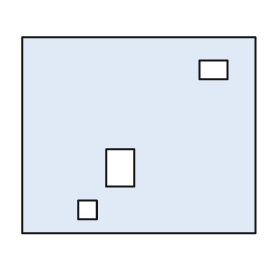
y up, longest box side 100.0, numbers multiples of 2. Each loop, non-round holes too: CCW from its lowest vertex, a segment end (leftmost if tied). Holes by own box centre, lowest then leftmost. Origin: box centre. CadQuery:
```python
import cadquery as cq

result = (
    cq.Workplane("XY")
    .moveTo(-50.0, -42.0)
    .lineTo(50.0, -42.0)
    .lineTo(50.0, 42.0)
    .lineTo(-50.0, 42.0)
    .close()
    .moveTo(-26.0, -36.0)
    .lineTo(-18.0, -36.0)
    .lineTo(-18.0, -28.0)
    .lineTo(-26.0, -28.0)
    .close()
    .moveTo(-14.0, -22.0)
    .lineTo(-2.0, -22.0)
    .lineTo(-2.0, -6.0)
    .lineTo(-14.0, -6.0)
    .close()
    .moveTo(26.0, 24.0)
    .lineTo(38.0, 24.0)
    .lineTo(38.0, 32.0)
    .lineTo(26.0, 32.0)
    .close()
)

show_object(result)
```